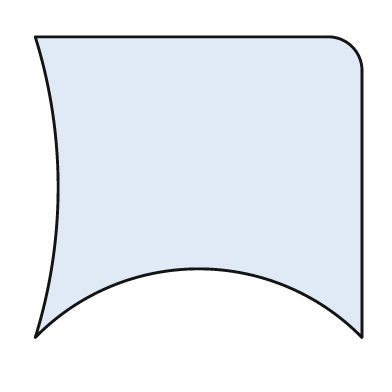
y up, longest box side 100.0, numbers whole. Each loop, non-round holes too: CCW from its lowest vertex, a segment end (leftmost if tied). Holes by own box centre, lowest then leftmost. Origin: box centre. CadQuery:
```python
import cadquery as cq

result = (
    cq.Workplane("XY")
    .moveTo(-50.0, -46.0)
    .threePointArc((0.0, -25.0), (50.0, -46.0))
    .lineTo(50.0, 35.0)
    .threePointArc((47.0, 43.0), (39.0, 46.0))
    .lineTo(-50.0, 46.0)
    .threePointArc((-43.0, 0.0), (-50.0, -46.0))
    .close()
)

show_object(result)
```